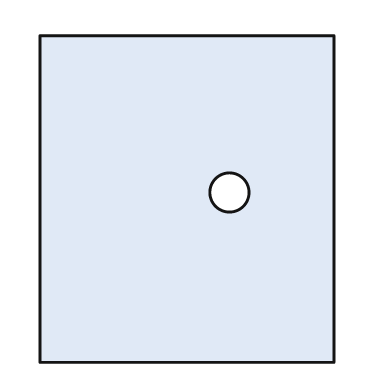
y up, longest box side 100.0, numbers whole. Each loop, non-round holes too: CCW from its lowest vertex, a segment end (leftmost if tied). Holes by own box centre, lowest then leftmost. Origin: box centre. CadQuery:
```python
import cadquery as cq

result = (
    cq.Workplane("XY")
    .moveTo(-45.0, -50.0)
    .lineTo(45.0, -50.0)
    .lineTo(45.0, 50.0)
    .lineTo(-45.0, 50.0)
    .close()
    .moveTo(13.0, 2.0)
    .circle(6.0)
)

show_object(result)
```